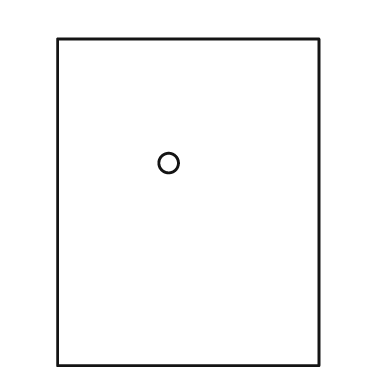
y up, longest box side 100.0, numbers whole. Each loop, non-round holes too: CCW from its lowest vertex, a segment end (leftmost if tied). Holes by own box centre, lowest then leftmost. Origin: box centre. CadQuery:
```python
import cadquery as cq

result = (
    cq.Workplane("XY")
    .moveTo(-40.0, -50.0)
    .lineTo(40.0, -50.0)
    .lineTo(40.0, 50.0)
    .lineTo(-40.0, 50.0)
    .close()
    .moveTo(-6.0, 12.0)
    .circle(3.0)
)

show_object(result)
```